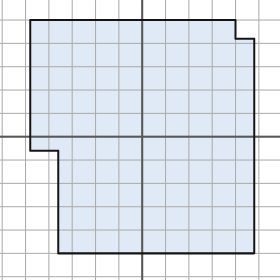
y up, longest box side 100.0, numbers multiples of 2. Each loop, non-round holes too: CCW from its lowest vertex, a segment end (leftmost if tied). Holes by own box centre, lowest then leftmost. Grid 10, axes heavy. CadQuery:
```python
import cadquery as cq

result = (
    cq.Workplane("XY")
    .moveTo(-36.0, -50.0)
    .lineTo(48.0, -50.0)
    .lineTo(48.0, 42.0)
    .lineTo(40.0, 42.0)
    .lineTo(40.0, 50.0)
    .lineTo(-48.0, 50.0)
    .lineTo(-48.0, -6.0)
    .lineTo(-36.0, -6.0)
    .close()
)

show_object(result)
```